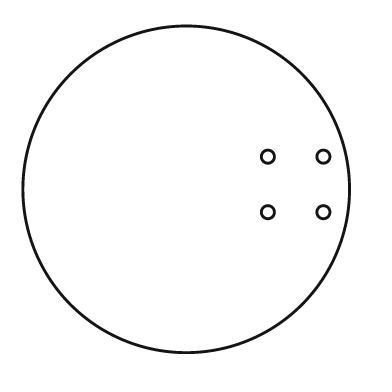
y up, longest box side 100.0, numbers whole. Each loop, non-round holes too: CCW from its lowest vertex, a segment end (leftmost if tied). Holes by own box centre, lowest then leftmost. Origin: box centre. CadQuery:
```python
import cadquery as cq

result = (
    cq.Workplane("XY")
    .moveTo(0.0, 0.0)
    .circle(50.0)
    .moveTo(25.0, -7.0)
    .circle(2.0)
    .moveTo(42.0, -7.0)
    .circle(2.0)
    .moveTo(25.0, 10.0)
    .circle(2.0)
    .moveTo(42.0, 10.0)
    .circle(2.0)
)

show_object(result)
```